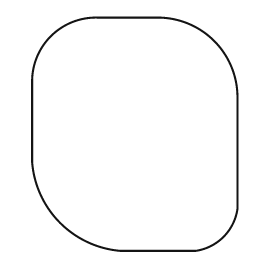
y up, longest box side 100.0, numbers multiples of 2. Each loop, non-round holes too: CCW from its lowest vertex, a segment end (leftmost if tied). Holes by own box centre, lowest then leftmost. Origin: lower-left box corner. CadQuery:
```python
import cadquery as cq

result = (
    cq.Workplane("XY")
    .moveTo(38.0, 0.0)
    .lineTo(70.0, 0.0)
    .threePointArc((82.0, 6.0), (88.0, 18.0))
    .lineTo(88.0, 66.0)
    .threePointArc((78.0, 90.0), (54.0, 100.0))
    .lineTo(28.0, 100.0)
    .threePointArc((8.0, 92.0), (0.0, 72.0))
    .lineTo(0.0, 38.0)
    .threePointArc((12.0, 12.0), (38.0, 0.0))
    .close()
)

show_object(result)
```